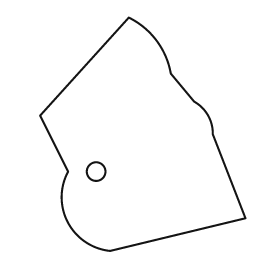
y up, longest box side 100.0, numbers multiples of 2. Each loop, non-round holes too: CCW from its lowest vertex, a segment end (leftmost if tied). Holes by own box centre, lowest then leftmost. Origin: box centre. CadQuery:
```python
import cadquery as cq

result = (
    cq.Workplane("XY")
    .moveTo(-14.0, -50.0)
    .lineTo(44.0, -36.0)
    .lineTo(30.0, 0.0)
    .threePointArc((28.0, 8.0), (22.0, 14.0))
    .lineTo(12.0, 26.0)
    .threePointArc((6.0, 40.0), (-6.0, 50.0))
    .lineTo(-44.0, 8.0)
    .lineTo(-32.0, -16.0)
    .threePointArc((-32.0, -38.0), (-14.0, -50.0))
    .close()
    .moveTo(-20.0, -16.0)
    .circle(4.0)
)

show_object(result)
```